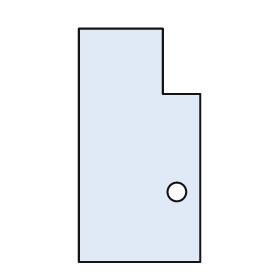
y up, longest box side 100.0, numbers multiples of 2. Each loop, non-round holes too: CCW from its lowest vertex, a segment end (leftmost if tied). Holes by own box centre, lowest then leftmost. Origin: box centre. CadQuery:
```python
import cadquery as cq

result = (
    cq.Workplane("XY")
    .moveTo(-26.0, -50.0)
    .lineTo(26.0, -50.0)
    .lineTo(26.0, 22.0)
    .lineTo(10.0, 22.0)
    .lineTo(10.0, 50.0)
    .lineTo(-26.0, 50.0)
    .close()
    .moveTo(16.0, -20.0)
    .circle(4.0)
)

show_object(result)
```